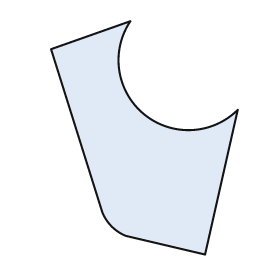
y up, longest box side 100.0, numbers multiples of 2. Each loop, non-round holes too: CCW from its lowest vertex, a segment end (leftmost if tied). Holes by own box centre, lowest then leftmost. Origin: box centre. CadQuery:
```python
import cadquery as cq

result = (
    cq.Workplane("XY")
    .moveTo(26.0, -50.0)
    .lineTo(40.0, 12.0)
    .threePointArc((0.0, 10.0), (-6.0, 50.0))
    .lineTo(-40.0, 38.0)
    .lineTo(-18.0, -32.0)
    .threePointArc((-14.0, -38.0), (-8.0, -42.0))
    .close()
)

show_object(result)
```